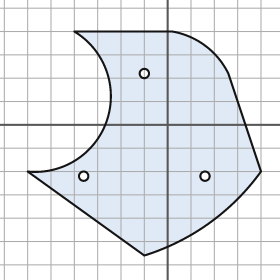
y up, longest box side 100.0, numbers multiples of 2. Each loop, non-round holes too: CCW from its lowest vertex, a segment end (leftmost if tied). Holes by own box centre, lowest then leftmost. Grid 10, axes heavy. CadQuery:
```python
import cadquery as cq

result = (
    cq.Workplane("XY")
    .moveTo(-10.0, -56.0)
    .threePointArc((18.0, -42.0), (40.0, -20.0))
    .lineTo(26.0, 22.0)
    .threePointArc((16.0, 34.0), (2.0, 40.0))
    .lineTo(-40.0, 40.0)
    .threePointArc((-26.0, 2.0), (-60.0, -20.0))
    .close()
    .moveTo(-36.0, -22.0)
    .circle(2.0)
    .moveTo(16.0, -22.0)
    .circle(2.0)
    .moveTo(-10.0, 22.0)
    .circle(2.0)
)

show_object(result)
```